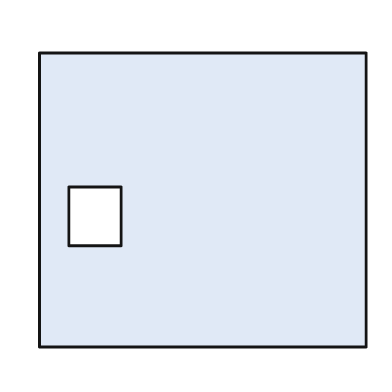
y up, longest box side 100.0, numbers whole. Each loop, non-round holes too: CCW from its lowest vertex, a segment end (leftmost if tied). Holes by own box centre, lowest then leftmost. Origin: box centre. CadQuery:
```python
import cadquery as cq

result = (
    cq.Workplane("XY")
    .moveTo(-50.0, -45.0)
    .lineTo(50.0, -45.0)
    .lineTo(50.0, 45.0)
    .lineTo(-50.0, 45.0)
    .close()
    .moveTo(-41.0, -14.0)
    .lineTo(-25.0, -14.0)
    .lineTo(-25.0, 4.0)
    .lineTo(-41.0, 4.0)
    .close()
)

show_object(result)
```